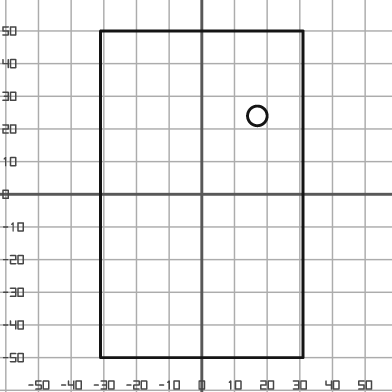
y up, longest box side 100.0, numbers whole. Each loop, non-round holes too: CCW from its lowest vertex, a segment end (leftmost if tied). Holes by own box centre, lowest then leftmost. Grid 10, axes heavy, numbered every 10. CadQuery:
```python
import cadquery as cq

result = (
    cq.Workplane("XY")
    .moveTo(-31.0, -50.0)
    .lineTo(31.0, -50.0)
    .lineTo(31.0, 50.0)
    .lineTo(-31.0, 50.0)
    .close()
    .moveTo(17.0, 24.0)
    .circle(3.0)
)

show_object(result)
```